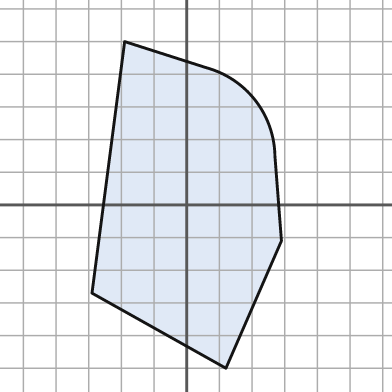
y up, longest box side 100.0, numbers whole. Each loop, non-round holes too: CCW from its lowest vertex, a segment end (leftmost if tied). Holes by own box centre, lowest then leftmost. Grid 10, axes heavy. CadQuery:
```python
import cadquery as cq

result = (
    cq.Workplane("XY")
    .moveTo(12.0, -50.0)
    .lineTo(29.0, -11.0)
    .lineTo(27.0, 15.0)
    .threePointArc((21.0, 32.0), (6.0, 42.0))
    .lineTo(-19.0, 50.0)
    .lineTo(-29.0, -27.0)
    .close()
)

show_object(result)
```